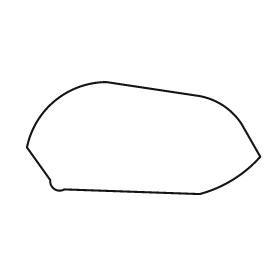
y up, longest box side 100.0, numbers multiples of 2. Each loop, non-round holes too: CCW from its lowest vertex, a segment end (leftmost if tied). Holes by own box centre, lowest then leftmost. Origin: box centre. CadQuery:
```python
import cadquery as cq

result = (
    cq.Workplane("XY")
    .moveTo(24.0, -24.0)
    .threePointArc((38.0, -18.0), (50.0, -8.0))
    .lineTo(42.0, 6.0)
    .threePointArc((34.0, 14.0), (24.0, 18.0))
    .lineTo(-16.0, 24.0)
    .threePointArc((-38.0, 16.0), (-50.0, -4.0))
    .lineTo(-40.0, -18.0)
    .threePointArc((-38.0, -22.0), (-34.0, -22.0))
    .close()
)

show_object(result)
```